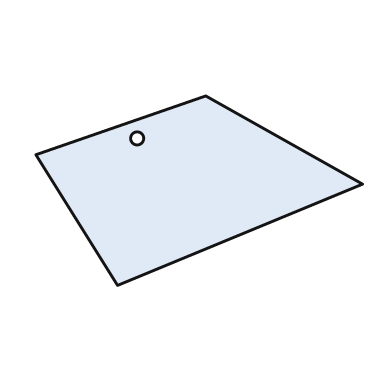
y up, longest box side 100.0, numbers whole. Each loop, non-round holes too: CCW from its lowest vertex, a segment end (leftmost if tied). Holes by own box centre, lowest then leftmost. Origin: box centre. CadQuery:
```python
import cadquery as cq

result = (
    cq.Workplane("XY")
    .moveTo(-25.0, -29.0)
    .lineTo(50.0, 2.0)
    .lineTo(2.0, 29.0)
    .lineTo(-50.0, 11.0)
    .close()
    .moveTo(-19.0, 16.0)
    .circle(2.0)
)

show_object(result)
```